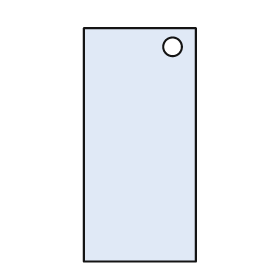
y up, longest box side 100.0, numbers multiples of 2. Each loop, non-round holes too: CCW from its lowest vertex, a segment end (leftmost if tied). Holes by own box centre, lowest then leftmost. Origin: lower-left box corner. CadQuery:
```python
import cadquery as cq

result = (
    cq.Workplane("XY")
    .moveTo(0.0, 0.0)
    .lineTo(48.0, 0.0)
    .lineTo(48.0, 100.0)
    .lineTo(0.0, 100.0)
    .close()
    .moveTo(38.0, 92.0)
    .circle(4.0)
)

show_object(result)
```